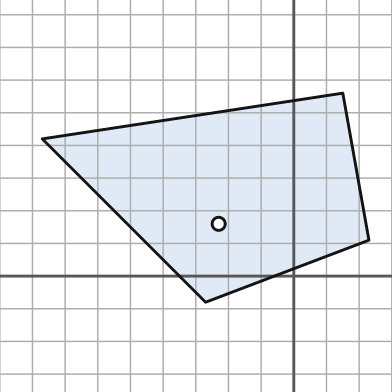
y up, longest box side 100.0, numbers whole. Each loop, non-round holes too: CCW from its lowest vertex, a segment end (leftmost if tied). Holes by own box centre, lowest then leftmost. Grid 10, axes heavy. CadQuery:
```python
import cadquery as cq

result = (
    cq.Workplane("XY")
    .moveTo(-27.0, -8.0)
    .lineTo(23.0, 11.0)
    .lineTo(15.0, 56.0)
    .lineTo(-77.0, 42.0)
    .close()
    .moveTo(-23.0, 16.0)
    .circle(2.0)
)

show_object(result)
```